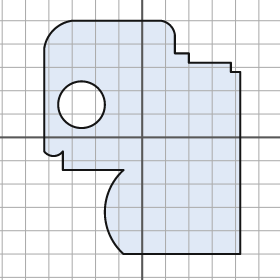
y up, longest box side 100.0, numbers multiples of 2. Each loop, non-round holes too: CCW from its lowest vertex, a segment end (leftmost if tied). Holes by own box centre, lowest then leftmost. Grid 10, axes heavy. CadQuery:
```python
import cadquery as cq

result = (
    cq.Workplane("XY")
    .moveTo(-8.0, -50.0)
    .lineTo(42.0, -50.0)
    .lineTo(42.0, 28.0)
    .lineTo(38.0, 28.0)
    .lineTo(38.0, 32.0)
    .lineTo(20.0, 32.0)
    .lineTo(20.0, 36.0)
    .lineTo(14.0, 36.0)
    .lineTo(14.0, 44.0)
    .threePointArc((12.0, 48.0), (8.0, 50.0))
    .lineTo(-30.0, 50.0)
    .threePointArc((-38.0, 46.0), (-42.0, 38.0))
    .lineTo(-42.0, -6.0)
    .threePointArc((-38.0, -8.0), (-34.0, -6.0))
    .lineTo(-34.0, -14.0)
    .lineTo(-8.0, -14.0)
    .threePointArc((-16.0, -32.0), (-8.0, -50.0))
    .close()
    .moveTo(-26.0, 14.0)
    .circle(10.0)
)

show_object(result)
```